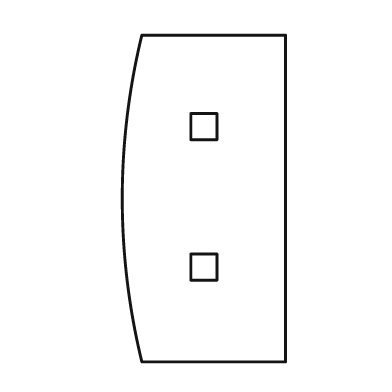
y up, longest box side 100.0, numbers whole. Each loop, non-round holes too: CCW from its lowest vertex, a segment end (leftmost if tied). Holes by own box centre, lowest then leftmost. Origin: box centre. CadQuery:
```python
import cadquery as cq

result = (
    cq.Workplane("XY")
    .moveTo(-19.0, -50.0)
    .lineTo(25.0, -50.0)
    .lineTo(25.0, 50.0)
    .lineTo(-19.0, 50.0)
    .threePointArc((-25.0, 0.0), (-19.0, -50.0))
    .close()
    .moveTo(-4.0, -25.0)
    .lineTo(4.0, -25.0)
    .lineTo(4.0, -17.0)
    .lineTo(-4.0, -17.0)
    .close()
    .moveTo(-4.0, 18.0)
    .lineTo(4.0, 18.0)
    .lineTo(4.0, 26.0)
    .lineTo(-4.0, 26.0)
    .close()
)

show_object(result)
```